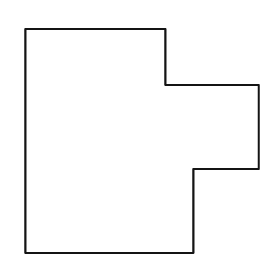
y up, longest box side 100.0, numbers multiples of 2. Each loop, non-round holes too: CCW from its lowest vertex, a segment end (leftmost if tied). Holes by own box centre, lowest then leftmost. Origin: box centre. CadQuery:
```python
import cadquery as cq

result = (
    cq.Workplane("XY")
    .moveTo(-50.0, -48.0)
    .lineTo(22.0, -48.0)
    .lineTo(22.0, -12.0)
    .lineTo(50.0, -12.0)
    .lineTo(50.0, 24.0)
    .lineTo(10.0, 24.0)
    .lineTo(10.0, 48.0)
    .lineTo(-50.0, 48.0)
    .close()
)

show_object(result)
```